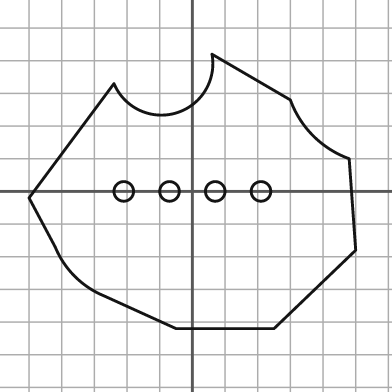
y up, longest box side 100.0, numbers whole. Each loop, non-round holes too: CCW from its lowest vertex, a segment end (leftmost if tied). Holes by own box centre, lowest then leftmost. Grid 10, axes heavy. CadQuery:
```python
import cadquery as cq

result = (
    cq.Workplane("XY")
    .moveTo(-5.0, -42.0)
    .lineTo(25.0, -42.0)
    .lineTo(50.0, -18.0)
    .lineTo(48.0, 10.0)
    .threePointArc((37.0, 17.0), (30.0, 28.0))
    .lineTo(6.0, 42.0)
    .threePointArc((-5.0, 24.0), (-24.0, 33.0))
    .lineTo(-50.0, -2.0)
    .lineTo(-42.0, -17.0)
    .threePointArc((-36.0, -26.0), (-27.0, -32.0))
    .close()
    .moveTo(-21.0, 0.0)
    .circle(3.0)
    .moveTo(-7.0, 0.0)
    .circle(3.0)
    .moveTo(7.0, 0.0)
    .circle(3.0)
    .moveTo(21.0, 0.0)
    .circle(3.0)
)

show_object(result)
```